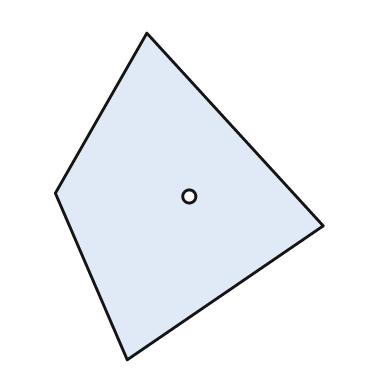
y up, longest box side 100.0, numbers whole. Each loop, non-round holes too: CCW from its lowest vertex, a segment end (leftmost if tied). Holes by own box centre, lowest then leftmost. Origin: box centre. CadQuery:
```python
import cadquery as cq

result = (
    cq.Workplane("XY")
    .moveTo(-19.0, -50.0)
    .lineTo(41.0, -9.0)
    .lineTo(-13.0, 50.0)
    .lineTo(-41.0, 1.0)
    .close()
    .moveTo(0.0, 0.0)
    .circle(2.0)
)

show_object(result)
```